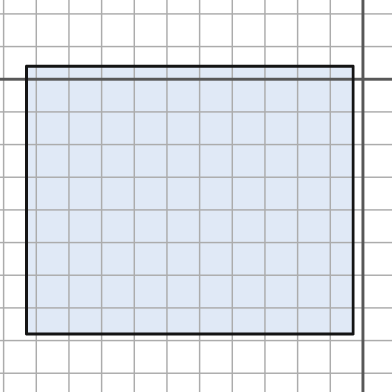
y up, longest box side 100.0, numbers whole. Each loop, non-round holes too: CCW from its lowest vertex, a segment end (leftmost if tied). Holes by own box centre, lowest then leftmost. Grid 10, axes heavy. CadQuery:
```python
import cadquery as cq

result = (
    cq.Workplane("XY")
    .moveTo(-103.0, -78.0)
    .lineTo(-3.0, -78.0)
    .lineTo(-3.0, 4.0)
    .lineTo(-103.0, 4.0)
    .close()
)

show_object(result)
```